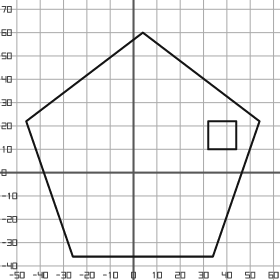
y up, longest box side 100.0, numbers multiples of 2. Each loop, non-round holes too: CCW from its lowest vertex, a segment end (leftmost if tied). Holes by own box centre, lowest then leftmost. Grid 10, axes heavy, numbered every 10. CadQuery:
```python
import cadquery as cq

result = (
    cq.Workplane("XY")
    .moveTo(-26.0, -36.0)
    .lineTo(34.0, -36.0)
    .lineTo(54.0, 22.0)
    .lineTo(4.0, 60.0)
    .lineTo(-46.0, 22.0)
    .close()
    .moveTo(32.0, 10.0)
    .lineTo(44.0, 10.0)
    .lineTo(44.0, 22.0)
    .lineTo(32.0, 22.0)
    .close()
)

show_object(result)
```